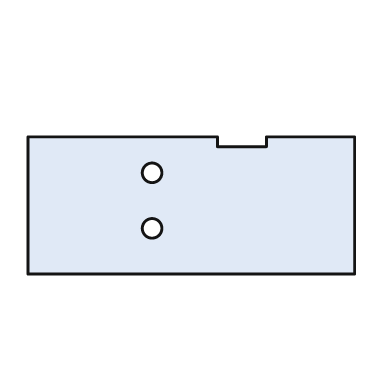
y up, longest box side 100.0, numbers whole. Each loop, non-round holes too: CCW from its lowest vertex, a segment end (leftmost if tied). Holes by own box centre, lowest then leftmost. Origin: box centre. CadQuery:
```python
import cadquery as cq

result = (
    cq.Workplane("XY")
    .moveTo(-50.0, -21.0)
    .lineTo(50.0, -21.0)
    .lineTo(50.0, 21.0)
    .lineTo(23.0, 21.0)
    .lineTo(23.0, 18.0)
    .lineTo(8.0, 18.0)
    .lineTo(8.0, 21.0)
    .lineTo(-50.0, 21.0)
    .close()
    .moveTo(-12.0, -7.0)
    .circle(3.0)
    .moveTo(-12.0, 10.0)
    .circle(3.0)
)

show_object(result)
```